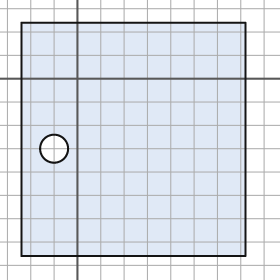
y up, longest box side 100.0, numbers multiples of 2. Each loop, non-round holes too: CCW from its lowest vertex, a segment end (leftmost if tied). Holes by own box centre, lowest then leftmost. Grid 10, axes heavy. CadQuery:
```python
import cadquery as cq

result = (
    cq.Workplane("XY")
    .moveTo(-24.0, -76.0)
    .lineTo(72.0, -76.0)
    .lineTo(72.0, 24.0)
    .lineTo(-24.0, 24.0)
    .close()
    .moveTo(-10.0, -30.0)
    .circle(6.0)
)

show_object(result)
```